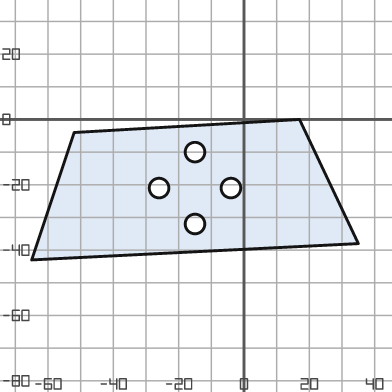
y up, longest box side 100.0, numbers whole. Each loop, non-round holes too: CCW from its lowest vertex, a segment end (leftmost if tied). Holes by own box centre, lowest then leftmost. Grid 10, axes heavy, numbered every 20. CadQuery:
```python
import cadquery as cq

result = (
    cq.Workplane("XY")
    .moveTo(-65.0, -43.0)
    .lineTo(35.0, -38.0)
    .lineTo(17.0, 0.0)
    .lineTo(-52.0, -4.0)
    .close()
    .moveTo(-15.0, -32.0)
    .circle(3.0)
    .moveTo(-26.0, -21.0)
    .circle(3.0)
    .moveTo(-4.0, -21.0)
    .circle(3.0)
    .moveTo(-15.0, -10.0)
    .circle(3.0)
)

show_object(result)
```